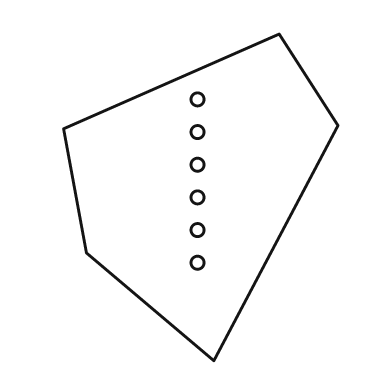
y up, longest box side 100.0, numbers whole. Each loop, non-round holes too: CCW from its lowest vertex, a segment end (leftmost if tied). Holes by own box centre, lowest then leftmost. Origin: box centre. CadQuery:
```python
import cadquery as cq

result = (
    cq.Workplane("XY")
    .moveTo(4.0, -50.0)
    .lineTo(42.0, 22.0)
    .lineTo(24.0, 50.0)
    .lineTo(-42.0, 21.0)
    .lineTo(-35.0, -17.0)
    .close()
    .moveTo(-1.0, -20.0)
    .circle(2.0)
    .moveTo(-1.0, -10.0)
    .circle(2.0)
    .moveTo(-1.0, 0.0)
    .circle(2.0)
    .moveTo(-1.0, 10.0)
    .circle(2.0)
    .moveTo(-1.0, 20.0)
    .circle(2.0)
    .moveTo(-1.0, 30.0)
    .circle(2.0)
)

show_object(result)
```